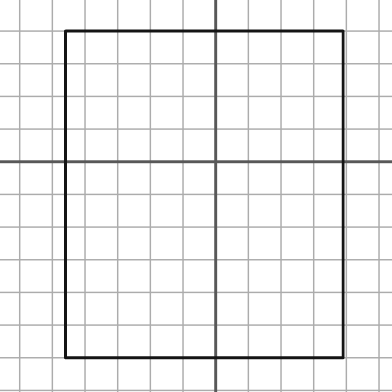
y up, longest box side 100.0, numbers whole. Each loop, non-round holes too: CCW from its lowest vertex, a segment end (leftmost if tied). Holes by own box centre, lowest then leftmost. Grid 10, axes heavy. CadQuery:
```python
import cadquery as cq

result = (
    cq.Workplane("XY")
    .moveTo(-46.0, -60.0)
    .lineTo(39.0, -60.0)
    .lineTo(39.0, 40.0)
    .lineTo(-46.0, 40.0)
    .close()
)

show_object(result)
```